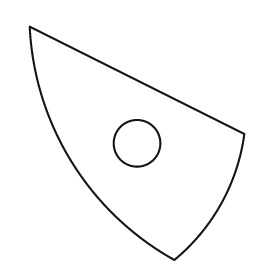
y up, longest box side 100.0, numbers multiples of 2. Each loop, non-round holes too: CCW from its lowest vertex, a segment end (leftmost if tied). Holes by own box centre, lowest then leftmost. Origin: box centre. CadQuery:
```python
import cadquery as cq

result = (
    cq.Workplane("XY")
    .moveTo(16.0, -50.0)
    .threePointArc((36.0, -26.0), (46.0, 4.0))
    .lineTo(-46.0, 50.0)
    .threePointArc((-28.0, -8.0), (16.0, -50.0))
    .close()
    .moveTo(0.0, 0.0)
    .circle(10.0)
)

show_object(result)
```